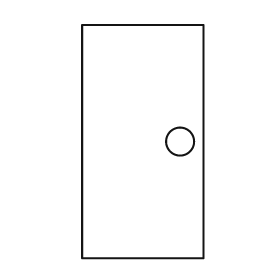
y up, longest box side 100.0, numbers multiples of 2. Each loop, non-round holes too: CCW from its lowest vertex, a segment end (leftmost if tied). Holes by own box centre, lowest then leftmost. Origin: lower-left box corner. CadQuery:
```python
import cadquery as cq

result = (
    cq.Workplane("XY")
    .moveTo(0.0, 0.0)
    .lineTo(52.0, 0.0)
    .lineTo(52.0, 100.0)
    .lineTo(0.0, 100.0)
    .close()
    .moveTo(42.0, 50.0)
    .circle(6.0)
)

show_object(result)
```